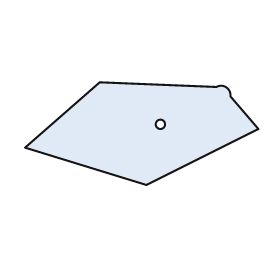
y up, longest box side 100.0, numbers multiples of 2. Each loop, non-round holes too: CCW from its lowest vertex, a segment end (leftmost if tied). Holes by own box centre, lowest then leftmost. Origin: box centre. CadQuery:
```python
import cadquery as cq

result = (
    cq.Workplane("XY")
    .moveTo(2.0, -22.0)
    .lineTo(50.0, 2.0)
    .lineTo(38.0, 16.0)
    .threePointArc((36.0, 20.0), (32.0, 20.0))
    .lineTo(-18.0, 22.0)
    .lineTo(-50.0, -6.0)
    .close()
    .moveTo(8.0, 4.0)
    .circle(2.0)
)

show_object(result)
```